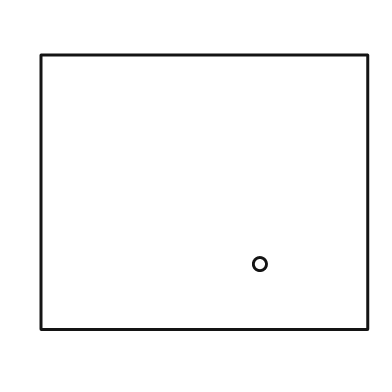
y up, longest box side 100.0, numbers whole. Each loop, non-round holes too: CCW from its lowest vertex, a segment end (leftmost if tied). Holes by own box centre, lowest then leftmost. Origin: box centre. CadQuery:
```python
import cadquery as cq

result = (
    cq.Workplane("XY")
    .moveTo(-50.0, -42.0)
    .lineTo(50.0, -42.0)
    .lineTo(50.0, 42.0)
    .lineTo(-50.0, 42.0)
    .close()
    .moveTo(17.0, -22.0)
    .circle(2.0)
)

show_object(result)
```